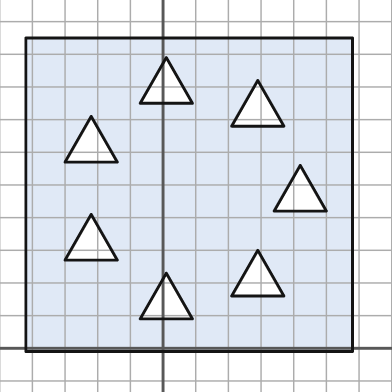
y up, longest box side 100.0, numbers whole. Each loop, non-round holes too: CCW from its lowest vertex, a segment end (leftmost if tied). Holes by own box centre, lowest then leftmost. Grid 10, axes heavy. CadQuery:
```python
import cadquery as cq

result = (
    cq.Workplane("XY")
    .moveTo(-42.0, -1.0)
    .lineTo(58.0, -1.0)
    .lineTo(58.0, 95.0)
    .lineTo(-42.0, 95.0)
    .close()
    .moveTo(-7.0, 9.0)
    .lineTo(9.0, 9.0)
    .lineTo(1.0, 23.0)
    .close()
    .moveTo(21.0, 16.0)
    .lineTo(37.0, 16.0)
    .lineTo(29.0, 30.0)
    .close()
    .moveTo(-30.0, 27.0)
    .lineTo(-14.0, 27.0)
    .lineTo(-22.0, 41.0)
    .close()
    .moveTo(34.0, 42.0)
    .lineTo(50.0, 42.0)
    .lineTo(42.0, 56.0)
    .close()
    .moveTo(-30.0, 57.0)
    .lineTo(-14.0, 57.0)
    .lineTo(-22.0, 71.0)
    .close()
    .moveTo(21.0, 68.0)
    .lineTo(37.0, 68.0)
    .lineTo(29.0, 82.0)
    .close()
    .moveTo(-7.0, 75.0)
    .lineTo(9.0, 75.0)
    .lineTo(1.0, 89.0)
    .close()
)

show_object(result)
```